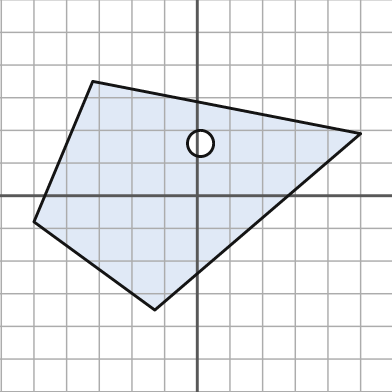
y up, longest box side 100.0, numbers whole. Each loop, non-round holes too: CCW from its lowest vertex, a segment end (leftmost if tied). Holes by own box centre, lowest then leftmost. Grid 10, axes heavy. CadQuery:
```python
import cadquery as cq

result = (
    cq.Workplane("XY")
    .moveTo(-13.0, -35.0)
    .lineTo(50.0, 19.0)
    .lineTo(-32.0, 35.0)
    .lineTo(-50.0, -8.0)
    .close()
    .moveTo(1.0, 16.0)
    .circle(4.0)
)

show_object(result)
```